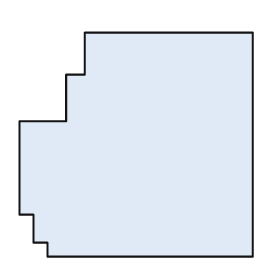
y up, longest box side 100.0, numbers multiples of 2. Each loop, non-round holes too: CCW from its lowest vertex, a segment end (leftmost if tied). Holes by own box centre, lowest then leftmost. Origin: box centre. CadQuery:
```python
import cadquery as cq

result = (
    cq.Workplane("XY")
    .moveTo(-38.0, -48.0)
    .lineTo(50.0, -48.0)
    .lineTo(50.0, 48.0)
    .lineTo(-22.0, 48.0)
    .lineTo(-22.0, 30.0)
    .lineTo(-30.0, 30.0)
    .lineTo(-30.0, 10.0)
    .lineTo(-50.0, 10.0)
    .lineTo(-50.0, -30.0)
    .lineTo(-44.0, -30.0)
    .lineTo(-44.0, -42.0)
    .lineTo(-38.0, -42.0)
    .close()
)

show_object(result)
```